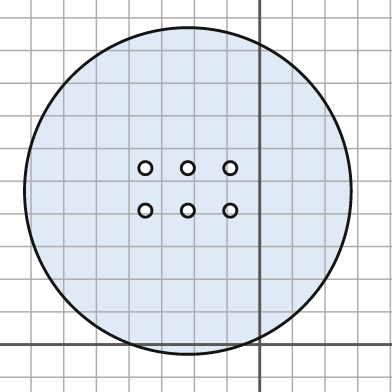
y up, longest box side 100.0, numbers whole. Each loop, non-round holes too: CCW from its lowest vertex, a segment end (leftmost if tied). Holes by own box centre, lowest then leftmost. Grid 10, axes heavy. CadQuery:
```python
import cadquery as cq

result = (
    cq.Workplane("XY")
    .moveTo(-22.0, 47.0)
    .circle(50.0)
    .moveTo(-35.0, 41.0)
    .circle(2.0)
    .moveTo(-22.0, 41.0)
    .circle(2.0)
    .moveTo(-9.0, 41.0)
    .circle(2.0)
    .moveTo(-35.0, 54.0)
    .circle(2.0)
    .moveTo(-22.0, 54.0)
    .circle(2.0)
    .moveTo(-9.0, 54.0)
    .circle(2.0)
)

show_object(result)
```